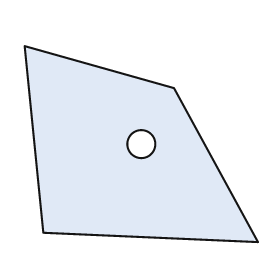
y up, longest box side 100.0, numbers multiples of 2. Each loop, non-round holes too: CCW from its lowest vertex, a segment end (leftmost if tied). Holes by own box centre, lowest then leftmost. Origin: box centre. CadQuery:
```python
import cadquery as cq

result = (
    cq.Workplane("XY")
    .moveTo(50.0, -42.0)
    .lineTo(14.0, 24.0)
    .lineTo(-50.0, 42.0)
    .lineTo(-42.0, -38.0)
    .close()
    .moveTo(0.0, 0.0)
    .circle(6.0)
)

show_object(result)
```